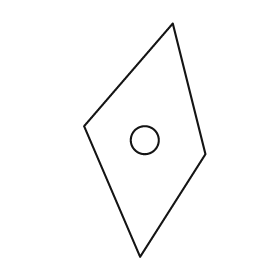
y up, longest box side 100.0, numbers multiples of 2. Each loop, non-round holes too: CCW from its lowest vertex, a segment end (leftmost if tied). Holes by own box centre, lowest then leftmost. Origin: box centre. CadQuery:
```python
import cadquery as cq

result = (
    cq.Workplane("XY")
    .moveTo(-2.0, -50.0)
    .lineTo(26.0, -6.0)
    .lineTo(12.0, 50.0)
    .lineTo(-26.0, 6.0)
    .close()
    .moveTo(0.0, 0.0)
    .circle(6.0)
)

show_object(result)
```